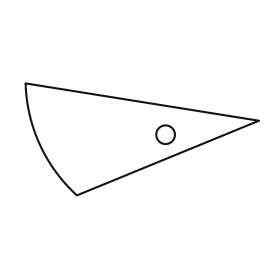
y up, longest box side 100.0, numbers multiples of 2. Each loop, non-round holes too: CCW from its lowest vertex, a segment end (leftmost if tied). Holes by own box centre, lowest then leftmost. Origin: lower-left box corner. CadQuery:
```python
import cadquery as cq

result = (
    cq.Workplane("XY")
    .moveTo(22.0, 0.0)
    .lineTo(100.0, 32.0)
    .lineTo(0.0, 48.0)
    .threePointArc((6.0, 22.0), (22.0, 0.0))
    .close()
    .moveTo(60.0, 26.0)
    .circle(4.0)
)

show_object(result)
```